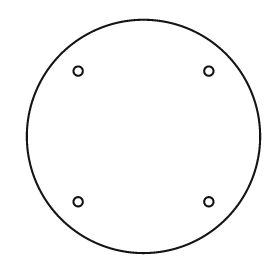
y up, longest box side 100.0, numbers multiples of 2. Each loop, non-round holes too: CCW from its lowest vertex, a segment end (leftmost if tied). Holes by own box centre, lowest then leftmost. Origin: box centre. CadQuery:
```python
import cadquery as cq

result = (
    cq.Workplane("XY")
    .moveTo(0.0, 0.0)
    .circle(50.0)
    .moveTo(-28.0, -28.0)
    .circle(2.0)
    .moveTo(28.0, -28.0)
    .circle(2.0)
    .moveTo(-28.0, 28.0)
    .circle(2.0)
    .moveTo(28.0, 28.0)
    .circle(2.0)
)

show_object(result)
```